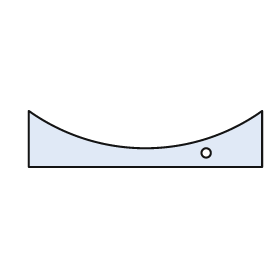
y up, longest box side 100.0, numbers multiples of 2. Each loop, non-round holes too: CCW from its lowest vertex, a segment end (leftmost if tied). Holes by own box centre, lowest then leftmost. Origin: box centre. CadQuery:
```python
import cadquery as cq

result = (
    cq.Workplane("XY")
    .moveTo(-50.0, -12.0)
    .lineTo(50.0, -12.0)
    .lineTo(50.0, 12.0)
    .threePointArc((0.0, -4.0), (-50.0, 12.0))
    .close()
    .moveTo(26.0, -6.0)
    .circle(2.0)
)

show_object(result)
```